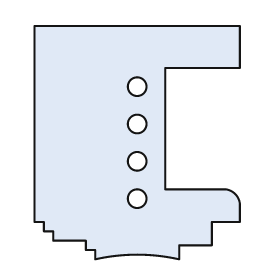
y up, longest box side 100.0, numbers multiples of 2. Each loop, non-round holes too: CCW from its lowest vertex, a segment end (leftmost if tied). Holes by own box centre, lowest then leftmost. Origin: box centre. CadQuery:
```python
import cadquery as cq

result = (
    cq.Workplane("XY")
    .moveTo(-18.0, -50.0)
    .threePointArc((0.0, -48.0), (18.0, -50.0))
    .lineTo(18.0, -44.0)
    .lineTo(32.0, -44.0)
    .lineTo(32.0, -34.0)
    .lineTo(44.0, -34.0)
    .lineTo(44.0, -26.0)
    .threePointArc((42.0, -22.0), (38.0, -20.0))
    .lineTo(12.0, -20.0)
    .lineTo(12.0, 32.0)
    .lineTo(44.0, 32.0)
    .lineTo(44.0, 50.0)
    .lineTo(-44.0, 50.0)
    .lineTo(-44.0, -34.0)
    .lineTo(-40.0, -34.0)
    .lineTo(-40.0, -38.0)
    .lineTo(-36.0, -38.0)
    .lineTo(-36.0, -42.0)
    .lineTo(-22.0, -42.0)
    .lineTo(-22.0, -46.0)
    .lineTo(-18.0, -46.0)
    .close()
    .moveTo(0.0, -24.0)
    .circle(4.0)
    .moveTo(0.0, -8.0)
    .circle(4.0)
    .moveTo(0.0, 8.0)
    .circle(4.0)
    .moveTo(0.0, 24.0)
    .circle(4.0)
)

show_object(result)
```